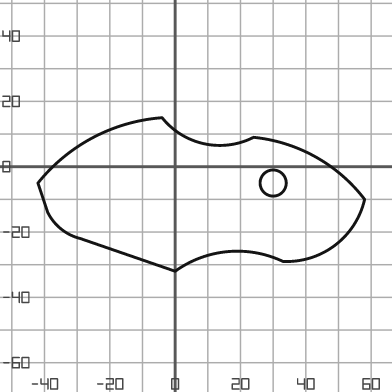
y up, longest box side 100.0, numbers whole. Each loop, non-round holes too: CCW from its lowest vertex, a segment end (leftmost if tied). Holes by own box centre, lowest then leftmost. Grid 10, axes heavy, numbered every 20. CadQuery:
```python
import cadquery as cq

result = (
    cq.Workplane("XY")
    .moveTo(0.0, -32.0)
    .threePointArc((16.0, -26.0), (33.0, -29.0))
    .threePointArc((49.0, -24.0), (58.0, -10.0))
    .threePointArc((43.0, 3.0), (24.0, 9.0))
    .threePointArc((9.0, 7.0), (-4.0, 15.0))
    .threePointArc((-25.0, 9.0), (-42.0, -5.0))
    .lineTo(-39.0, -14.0)
    .threePointArc((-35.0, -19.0), (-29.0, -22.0))
    .close()
    .moveTo(30.0, -5.0)
    .circle(4.0)
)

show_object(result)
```